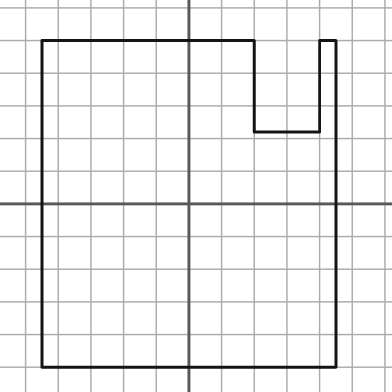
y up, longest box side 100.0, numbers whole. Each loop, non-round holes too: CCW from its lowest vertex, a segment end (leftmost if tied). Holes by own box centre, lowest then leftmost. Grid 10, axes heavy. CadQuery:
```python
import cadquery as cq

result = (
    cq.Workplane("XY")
    .moveTo(-45.0, -50.0)
    .lineTo(45.0, -50.0)
    .lineTo(45.0, 50.0)
    .lineTo(40.0, 50.0)
    .lineTo(40.0, 22.0)
    .lineTo(20.0, 22.0)
    .lineTo(20.0, 50.0)
    .lineTo(-45.0, 50.0)
    .close()
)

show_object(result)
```